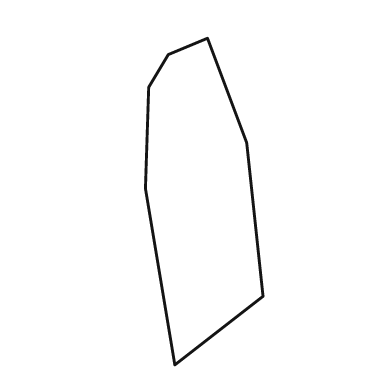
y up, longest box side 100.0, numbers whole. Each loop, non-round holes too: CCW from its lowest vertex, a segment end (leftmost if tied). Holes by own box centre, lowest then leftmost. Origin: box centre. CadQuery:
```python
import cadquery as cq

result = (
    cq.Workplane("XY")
    .moveTo(-9.0, -50.0)
    .lineTo(18.0, -29.0)
    .lineTo(13.0, 18.0)
    .lineTo(1.0, 50.0)
    .lineTo(-11.0, 45.0)
    .lineTo(-17.0, 35.0)
    .lineTo(-18.0, 4.0)
    .close()
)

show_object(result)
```